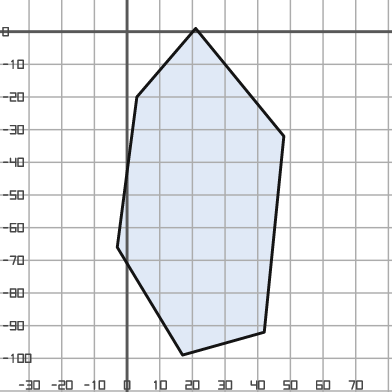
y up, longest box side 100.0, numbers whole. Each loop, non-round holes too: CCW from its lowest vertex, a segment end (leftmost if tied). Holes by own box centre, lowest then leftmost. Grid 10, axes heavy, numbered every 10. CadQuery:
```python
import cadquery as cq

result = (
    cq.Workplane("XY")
    .moveTo(17.0, -99.0)
    .lineTo(42.0, -92.0)
    .lineTo(48.0, -32.0)
    .lineTo(21.0, 1.0)
    .lineTo(3.0, -20.0)
    .lineTo(-3.0, -66.0)
    .close()
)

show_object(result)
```